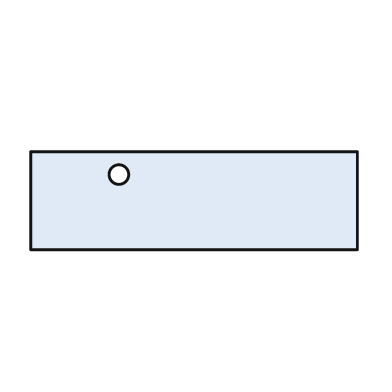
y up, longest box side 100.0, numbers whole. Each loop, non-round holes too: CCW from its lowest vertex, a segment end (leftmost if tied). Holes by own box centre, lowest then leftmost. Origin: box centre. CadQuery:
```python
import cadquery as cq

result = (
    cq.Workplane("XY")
    .moveTo(-50.0, -15.0)
    .lineTo(50.0, -15.0)
    .lineTo(50.0, 15.0)
    .lineTo(-50.0, 15.0)
    .close()
    .moveTo(-23.0, 8.0)
    .circle(3.0)
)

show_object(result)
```